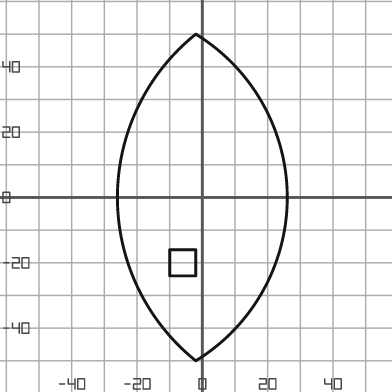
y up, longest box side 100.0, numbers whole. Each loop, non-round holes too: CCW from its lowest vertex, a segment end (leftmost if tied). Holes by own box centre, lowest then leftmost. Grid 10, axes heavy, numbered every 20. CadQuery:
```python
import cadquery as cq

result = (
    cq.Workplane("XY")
    .moveTo(-2.0, -50.0)
    .threePointArc((26.0, 0.0), (-2.0, 50.0))
    .threePointArc((-26.0, 0.0), (-2.0, -50.0))
    .close()
    .moveTo(-10.0, -24.0)
    .lineTo(-2.0, -24.0)
    .lineTo(-2.0, -16.0)
    .lineTo(-10.0, -16.0)
    .close()
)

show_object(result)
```